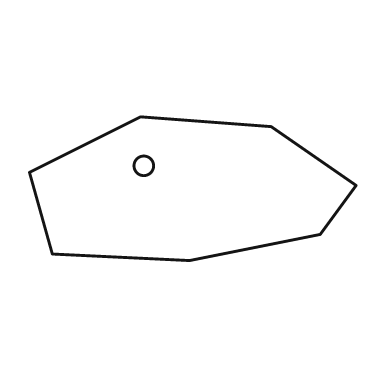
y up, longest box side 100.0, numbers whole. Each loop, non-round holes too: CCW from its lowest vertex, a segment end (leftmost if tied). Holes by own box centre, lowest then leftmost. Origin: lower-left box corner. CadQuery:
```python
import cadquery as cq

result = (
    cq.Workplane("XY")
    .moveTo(49.0, 0.0)
    .lineTo(89.0, 8.0)
    .lineTo(100.0, 23.0)
    .lineTo(74.0, 41.0)
    .lineTo(34.0, 44.0)
    .lineTo(0.0, 27.0)
    .lineTo(7.0, 2.0)
    .close()
    .moveTo(35.0, 29.0)
    .circle(3.0)
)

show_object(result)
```